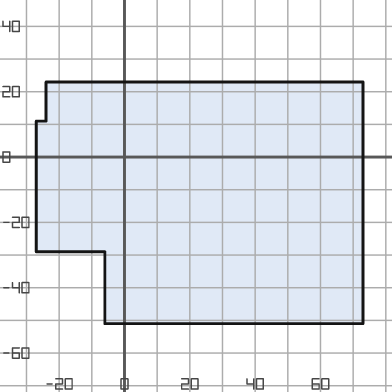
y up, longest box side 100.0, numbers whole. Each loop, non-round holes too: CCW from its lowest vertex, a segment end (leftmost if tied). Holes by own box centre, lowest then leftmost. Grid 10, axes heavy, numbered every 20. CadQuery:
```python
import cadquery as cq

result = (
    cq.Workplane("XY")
    .moveTo(-6.0, -51.0)
    .lineTo(73.0, -51.0)
    .lineTo(73.0, 23.0)
    .lineTo(-24.0, 23.0)
    .lineTo(-24.0, 11.0)
    .lineTo(-27.0, 11.0)
    .lineTo(-27.0, -29.0)
    .lineTo(-6.0, -29.0)
    .close()
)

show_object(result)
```